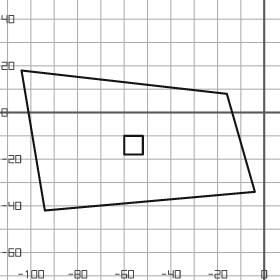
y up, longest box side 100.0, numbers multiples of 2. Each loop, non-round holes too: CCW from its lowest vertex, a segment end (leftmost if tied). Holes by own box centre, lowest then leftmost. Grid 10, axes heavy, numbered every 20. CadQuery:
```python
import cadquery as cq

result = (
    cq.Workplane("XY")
    .moveTo(-94.0, -42.0)
    .lineTo(-4.0, -34.0)
    .lineTo(-16.0, 8.0)
    .lineTo(-104.0, 18.0)
    .close()
    .moveTo(-60.0, -18.0)
    .lineTo(-52.0, -18.0)
    .lineTo(-52.0, -10.0)
    .lineTo(-60.0, -10.0)
    .close()
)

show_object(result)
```